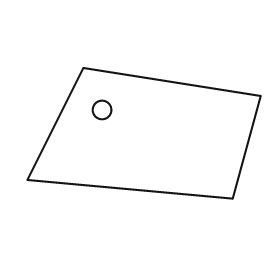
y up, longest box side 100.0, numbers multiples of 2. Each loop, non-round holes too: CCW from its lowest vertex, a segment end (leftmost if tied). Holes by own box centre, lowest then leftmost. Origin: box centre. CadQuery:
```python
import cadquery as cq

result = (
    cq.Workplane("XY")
    .moveTo(38.0, -28.0)
    .lineTo(50.0, 16.0)
    .lineTo(-26.0, 28.0)
    .lineTo(-50.0, -20.0)
    .close()
    .moveTo(-18.0, 10.0)
    .circle(4.0)
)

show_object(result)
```